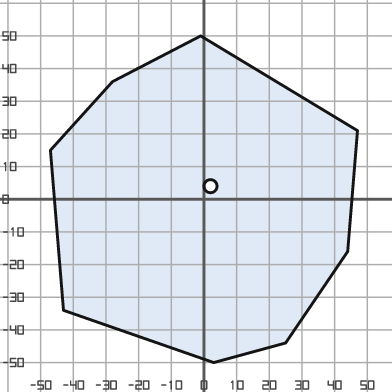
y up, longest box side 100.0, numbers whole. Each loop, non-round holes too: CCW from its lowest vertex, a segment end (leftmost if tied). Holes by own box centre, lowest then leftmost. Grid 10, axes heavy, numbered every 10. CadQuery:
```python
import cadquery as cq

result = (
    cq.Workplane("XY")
    .moveTo(3.0, -50.0)
    .lineTo(25.0, -44.0)
    .lineTo(44.0, -16.0)
    .lineTo(47.0, 21.0)
    .lineTo(-1.0, 50.0)
    .lineTo(-28.0, 36.0)
    .lineTo(-47.0, 15.0)
    .lineTo(-43.0, -34.0)
    .close()
    .moveTo(2.0, 4.0)
    .circle(2.0)
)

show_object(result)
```